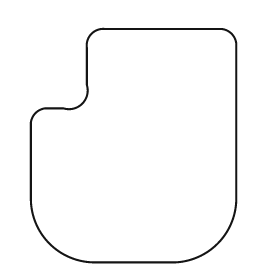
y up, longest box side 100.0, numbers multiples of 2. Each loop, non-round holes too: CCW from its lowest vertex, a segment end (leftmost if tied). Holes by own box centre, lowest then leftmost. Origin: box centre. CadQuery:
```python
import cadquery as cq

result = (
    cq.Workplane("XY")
    .moveTo(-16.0, -50.0)
    .lineTo(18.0, -50.0)
    .threePointArc((36.0, -42.0), (44.0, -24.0))
    .lineTo(44.0, 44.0)
    .threePointArc((42.0, 48.0), (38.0, 50.0))
    .lineTo(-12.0, 50.0)
    .threePointArc((-18.0, 48.0), (-20.0, 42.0))
    .lineTo(-20.0, 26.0)
    .threePointArc((-22.0, 18.0), (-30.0, 16.0))
    .lineTo(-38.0, 16.0)
    .threePointArc((-42.0, 14.0), (-44.0, 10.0))
    .lineTo(-44.0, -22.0)
    .threePointArc((-36.0, -42.0), (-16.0, -50.0))
    .close()
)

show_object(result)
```